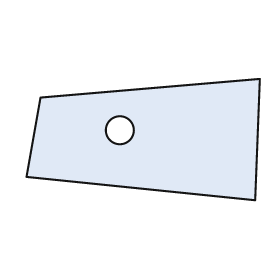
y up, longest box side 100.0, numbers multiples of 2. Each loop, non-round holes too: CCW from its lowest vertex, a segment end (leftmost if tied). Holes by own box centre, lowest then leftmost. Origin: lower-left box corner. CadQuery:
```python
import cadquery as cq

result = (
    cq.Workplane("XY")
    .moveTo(98.0, 0.0)
    .lineTo(100.0, 52.0)
    .lineTo(6.0, 44.0)
    .lineTo(0.0, 10.0)
    .close()
    .moveTo(40.0, 30.0)
    .circle(6.0)
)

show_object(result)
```